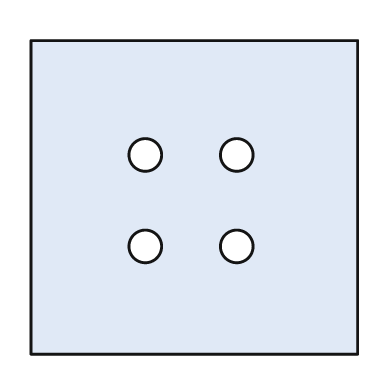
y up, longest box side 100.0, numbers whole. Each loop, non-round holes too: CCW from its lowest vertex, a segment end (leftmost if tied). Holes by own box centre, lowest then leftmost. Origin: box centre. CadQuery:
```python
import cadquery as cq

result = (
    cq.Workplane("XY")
    .moveTo(-50.0, -48.0)
    .lineTo(50.0, -48.0)
    .lineTo(50.0, 48.0)
    .lineTo(-50.0, 48.0)
    .close()
    .moveTo(-15.0, -15.0)
    .circle(5.0)
    .moveTo(13.0, -15.0)
    .circle(5.0)
    .moveTo(-15.0, 13.0)
    .circle(5.0)
    .moveTo(13.0, 13.0)
    .circle(5.0)
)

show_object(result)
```